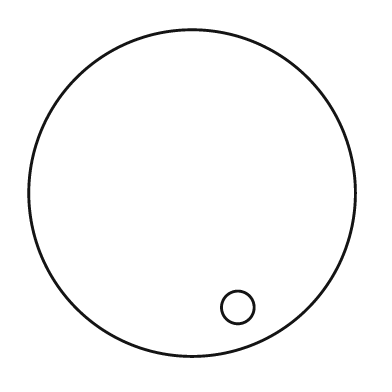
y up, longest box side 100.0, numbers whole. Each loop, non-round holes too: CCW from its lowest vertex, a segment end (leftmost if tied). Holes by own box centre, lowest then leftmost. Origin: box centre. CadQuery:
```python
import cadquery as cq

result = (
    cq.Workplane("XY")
    .moveTo(0.0, 0.0)
    .circle(50.0)
    .moveTo(14.0, -35.0)
    .circle(5.0)
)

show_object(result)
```